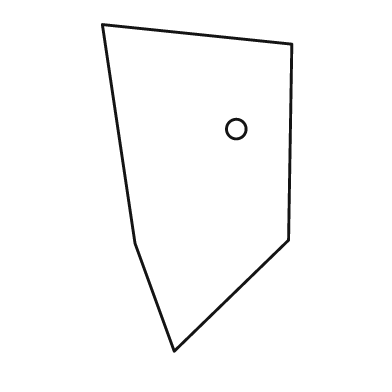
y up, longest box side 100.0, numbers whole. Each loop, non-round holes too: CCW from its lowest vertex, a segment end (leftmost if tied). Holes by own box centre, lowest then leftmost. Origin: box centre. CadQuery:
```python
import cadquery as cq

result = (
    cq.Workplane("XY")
    .moveTo(-7.0, -50.0)
    .lineTo(28.0, -16.0)
    .lineTo(29.0, 44.0)
    .lineTo(-29.0, 50.0)
    .lineTo(-19.0, -17.0)
    .close()
    .moveTo(12.0, 18.0)
    .circle(3.0)
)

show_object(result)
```